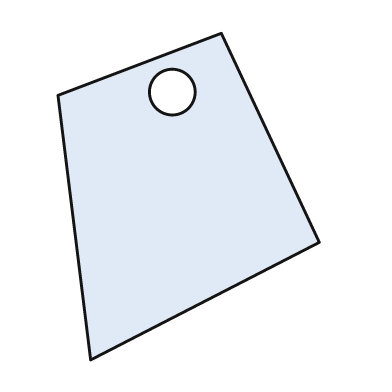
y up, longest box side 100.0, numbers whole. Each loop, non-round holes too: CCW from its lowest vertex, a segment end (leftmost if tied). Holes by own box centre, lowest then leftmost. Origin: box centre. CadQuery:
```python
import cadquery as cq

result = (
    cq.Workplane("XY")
    .moveTo(-30.0, -50.0)
    .lineTo(40.0, -14.0)
    .lineTo(10.0, 50.0)
    .lineTo(-40.0, 31.0)
    .close()
    .moveTo(-5.0, 32.0)
    .circle(7.0)
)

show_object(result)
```